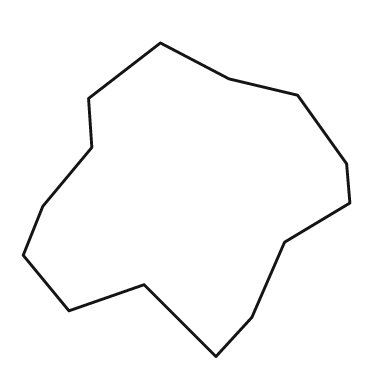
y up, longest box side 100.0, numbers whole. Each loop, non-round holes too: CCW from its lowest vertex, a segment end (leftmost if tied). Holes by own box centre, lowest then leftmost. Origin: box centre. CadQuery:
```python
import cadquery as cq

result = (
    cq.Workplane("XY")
    .moveTo(9.0, -48.0)
    .lineTo(20.0, -36.0)
    .lineTo(30.0, -13.0)
    .lineTo(50.0, -1.0)
    .lineTo(49.0, 11.0)
    .lineTo(34.0, 32.0)
    .lineTo(13.0, 37.0)
    .lineTo(-8.0, 48.0)
    .lineTo(-30.0, 31.0)
    .lineTo(-29.0, 16.0)
    .lineTo(-44.0, -2.0)
    .lineTo(-50.0, -17.0)
    .lineTo(-36.0, -34.0)
    .lineTo(-13.0, -26.0)
    .close()
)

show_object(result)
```